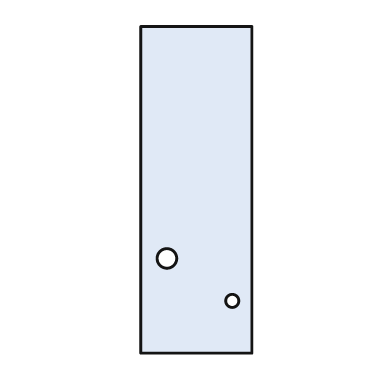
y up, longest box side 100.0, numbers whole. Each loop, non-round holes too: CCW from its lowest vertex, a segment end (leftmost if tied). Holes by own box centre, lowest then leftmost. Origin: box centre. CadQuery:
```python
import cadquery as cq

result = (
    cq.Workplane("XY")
    .moveTo(-17.0, -50.0)
    .lineTo(17.0, -50.0)
    .lineTo(17.0, 50.0)
    .lineTo(-17.0, 50.0)
    .close()
    .moveTo(11.0, -34.0)
    .circle(2.0)
    .moveTo(-9.0, -21.0)
    .circle(3.0)
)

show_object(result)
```